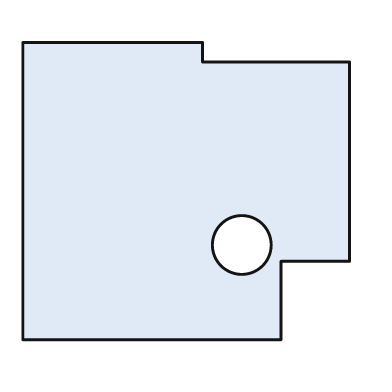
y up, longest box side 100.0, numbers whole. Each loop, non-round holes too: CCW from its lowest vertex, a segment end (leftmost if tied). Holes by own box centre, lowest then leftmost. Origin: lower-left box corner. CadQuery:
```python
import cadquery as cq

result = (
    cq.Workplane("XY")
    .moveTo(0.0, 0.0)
    .lineTo(79.0, 0.0)
    .lineTo(79.0, 24.0)
    .lineTo(100.0, 24.0)
    .lineTo(100.0, 85.0)
    .lineTo(55.0, 85.0)
    .lineTo(55.0, 91.0)
    .lineTo(0.0, 91.0)
    .close()
    .moveTo(67.0, 29.0)
    .circle(9.0)
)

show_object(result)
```